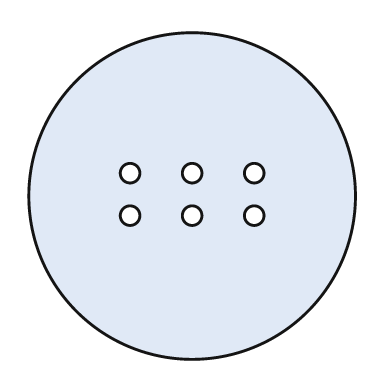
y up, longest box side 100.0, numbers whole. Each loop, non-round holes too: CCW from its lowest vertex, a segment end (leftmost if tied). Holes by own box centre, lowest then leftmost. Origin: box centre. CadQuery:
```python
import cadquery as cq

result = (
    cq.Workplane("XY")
    .moveTo(0.0, 0.0)
    .circle(50.0)
    .moveTo(-19.0, -6.0)
    .circle(3.0)
    .moveTo(0.0, -6.0)
    .circle(3.0)
    .moveTo(19.0, -6.0)
    .circle(3.0)
    .moveTo(-19.0, 7.0)
    .circle(3.0)
    .moveTo(0.0, 7.0)
    .circle(3.0)
    .moveTo(19.0, 7.0)
    .circle(3.0)
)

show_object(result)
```